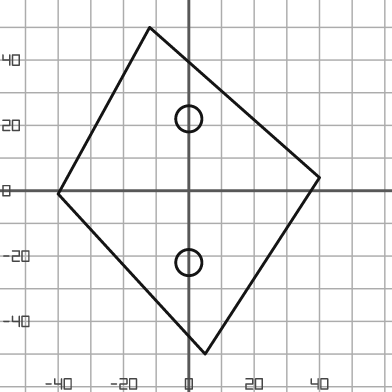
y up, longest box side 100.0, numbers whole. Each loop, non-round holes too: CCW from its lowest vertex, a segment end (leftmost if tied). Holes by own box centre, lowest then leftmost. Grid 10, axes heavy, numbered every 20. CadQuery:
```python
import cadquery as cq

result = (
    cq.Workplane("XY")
    .moveTo(5.0, -50.0)
    .lineTo(40.0, 4.0)
    .lineTo(-12.0, 50.0)
    .lineTo(-40.0, -1.0)
    .close()
    .moveTo(0.0, -22.0)
    .circle(4.0)
    .moveTo(0.0, 22.0)
    .circle(4.0)
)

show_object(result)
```